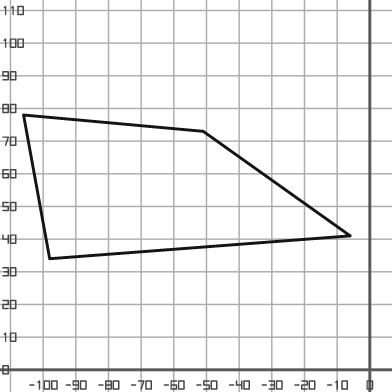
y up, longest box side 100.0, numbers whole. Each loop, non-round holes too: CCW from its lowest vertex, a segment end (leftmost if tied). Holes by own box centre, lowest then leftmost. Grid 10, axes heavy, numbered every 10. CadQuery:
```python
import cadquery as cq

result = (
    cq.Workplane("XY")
    .moveTo(-98.0, 34.0)
    .lineTo(-6.0, 41.0)
    .lineTo(-51.0, 73.0)
    .lineTo(-106.0, 78.0)
    .close()
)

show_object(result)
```